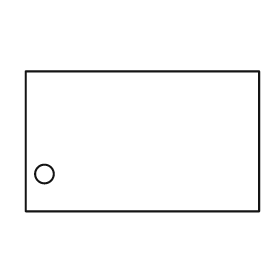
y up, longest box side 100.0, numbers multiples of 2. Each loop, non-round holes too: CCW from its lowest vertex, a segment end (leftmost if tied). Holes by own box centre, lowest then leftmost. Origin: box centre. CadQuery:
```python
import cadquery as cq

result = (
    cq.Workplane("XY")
    .moveTo(-50.0, -30.0)
    .lineTo(50.0, -30.0)
    .lineTo(50.0, 30.0)
    .lineTo(-50.0, 30.0)
    .close()
    .moveTo(-42.0, -14.0)
    .circle(4.0)
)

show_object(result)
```